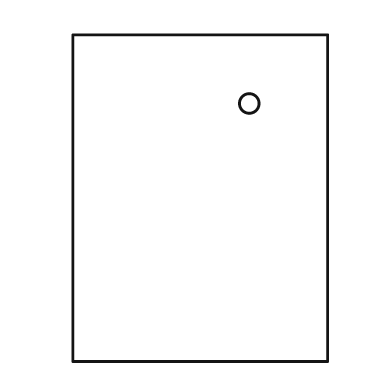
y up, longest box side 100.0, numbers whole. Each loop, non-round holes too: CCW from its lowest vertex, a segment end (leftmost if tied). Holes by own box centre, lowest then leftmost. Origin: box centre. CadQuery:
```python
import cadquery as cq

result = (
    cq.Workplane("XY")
    .moveTo(-39.0, -50.0)
    .lineTo(39.0, -50.0)
    .lineTo(39.0, 50.0)
    .lineTo(-39.0, 50.0)
    .close()
    .moveTo(15.0, 29.0)
    .circle(3.0)
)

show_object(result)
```